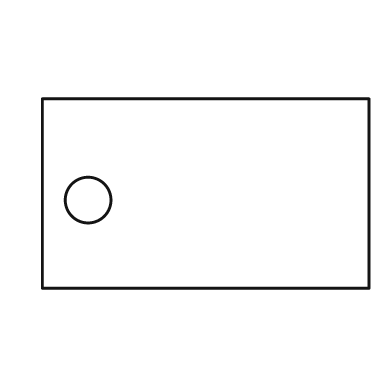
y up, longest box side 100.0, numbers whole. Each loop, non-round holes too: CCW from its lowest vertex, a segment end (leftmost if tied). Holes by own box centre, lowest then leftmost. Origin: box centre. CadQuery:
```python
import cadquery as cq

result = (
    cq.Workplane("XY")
    .moveTo(-50.0, -29.0)
    .lineTo(50.0, -29.0)
    .lineTo(50.0, 29.0)
    .lineTo(-50.0, 29.0)
    .close()
    .moveTo(-36.0, -2.0)
    .circle(7.0)
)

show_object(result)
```